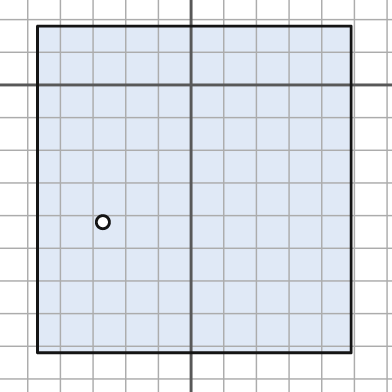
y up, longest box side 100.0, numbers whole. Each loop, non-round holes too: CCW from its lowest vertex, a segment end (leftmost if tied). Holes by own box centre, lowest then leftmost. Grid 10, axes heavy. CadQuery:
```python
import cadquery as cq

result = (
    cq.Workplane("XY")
    .moveTo(-47.0, -82.0)
    .lineTo(49.0, -82.0)
    .lineTo(49.0, 18.0)
    .lineTo(-47.0, 18.0)
    .close()
    .moveTo(-27.0, -42.0)
    .circle(2.0)
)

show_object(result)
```